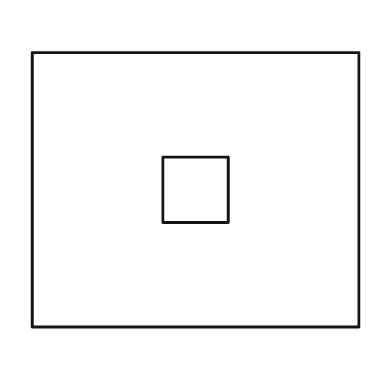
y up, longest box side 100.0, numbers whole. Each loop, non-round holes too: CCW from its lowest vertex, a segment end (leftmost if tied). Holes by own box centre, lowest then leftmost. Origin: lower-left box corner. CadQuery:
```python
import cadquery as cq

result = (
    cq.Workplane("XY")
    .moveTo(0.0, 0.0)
    .lineTo(100.0, 0.0)
    .lineTo(100.0, 84.0)
    .lineTo(0.0, 84.0)
    .close()
    .moveTo(40.0, 32.0)
    .lineTo(60.0, 32.0)
    .lineTo(60.0, 52.0)
    .lineTo(40.0, 52.0)
    .close()
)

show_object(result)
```